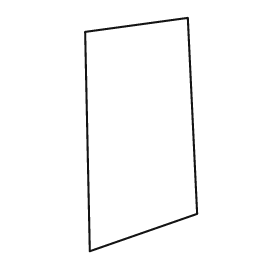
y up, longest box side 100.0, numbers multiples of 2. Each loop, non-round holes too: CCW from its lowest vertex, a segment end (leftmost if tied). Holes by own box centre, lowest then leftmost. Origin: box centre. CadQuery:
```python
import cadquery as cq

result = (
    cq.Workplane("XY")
    .moveTo(-22.0, -50.0)
    .lineTo(24.0, -34.0)
    .lineTo(20.0, 50.0)
    .lineTo(-24.0, 44.0)
    .close()
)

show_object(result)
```